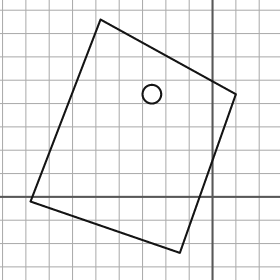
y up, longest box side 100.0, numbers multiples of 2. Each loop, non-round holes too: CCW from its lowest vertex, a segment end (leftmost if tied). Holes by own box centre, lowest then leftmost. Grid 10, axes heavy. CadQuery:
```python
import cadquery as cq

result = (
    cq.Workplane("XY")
    .moveTo(-14.0, -24.0)
    .lineTo(10.0, 44.0)
    .lineTo(-48.0, 76.0)
    .lineTo(-78.0, -2.0)
    .close()
    .moveTo(-26.0, 44.0)
    .circle(4.0)
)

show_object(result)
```